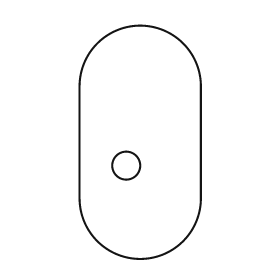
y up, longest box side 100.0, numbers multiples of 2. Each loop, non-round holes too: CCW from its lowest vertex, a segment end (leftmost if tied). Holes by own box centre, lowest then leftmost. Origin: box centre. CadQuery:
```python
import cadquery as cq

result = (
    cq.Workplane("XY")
    .moveTo(-26.0, -24.0)
    .threePointArc((0.0, -50.0), (26.0, -24.0))
    .lineTo(26.0, 24.0)
    .threePointArc((0.0, 50.0), (-26.0, 24.0))
    .close()
    .moveTo(-6.0, -10.0)
    .circle(6.0)
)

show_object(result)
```